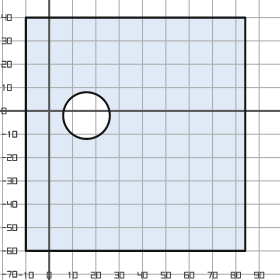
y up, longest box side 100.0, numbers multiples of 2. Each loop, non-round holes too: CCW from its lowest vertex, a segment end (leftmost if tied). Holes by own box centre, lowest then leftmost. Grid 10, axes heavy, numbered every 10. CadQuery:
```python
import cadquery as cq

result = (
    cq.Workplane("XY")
    .moveTo(-10.0, -60.0)
    .lineTo(84.0, -60.0)
    .lineTo(84.0, 40.0)
    .lineTo(-10.0, 40.0)
    .close()
    .moveTo(16.0, -2.0)
    .circle(10.0)
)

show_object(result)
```